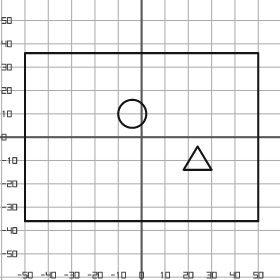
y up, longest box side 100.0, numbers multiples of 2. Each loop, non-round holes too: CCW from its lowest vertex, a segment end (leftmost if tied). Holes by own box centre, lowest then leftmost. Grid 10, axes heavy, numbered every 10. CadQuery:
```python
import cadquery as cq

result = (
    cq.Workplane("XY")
    .moveTo(-50.0, -36.0)
    .lineTo(50.0, -36.0)
    .lineTo(50.0, 36.0)
    .lineTo(-50.0, 36.0)
    .close()
    .moveTo(18.0, -14.0)
    .lineTo(30.0, -14.0)
    .lineTo(24.0, -4.0)
    .close()
    .moveTo(-4.0, 10.0)
    .circle(6.0)
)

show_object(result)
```